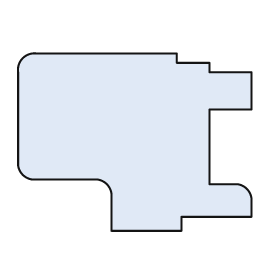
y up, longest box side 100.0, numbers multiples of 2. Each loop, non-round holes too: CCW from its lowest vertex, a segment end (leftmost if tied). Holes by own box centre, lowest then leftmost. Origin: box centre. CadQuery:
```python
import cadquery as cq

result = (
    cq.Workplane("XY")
    .moveTo(-10.0, -38.0)
    .lineTo(20.0, -38.0)
    .lineTo(20.0, -32.0)
    .lineTo(50.0, -32.0)
    .lineTo(50.0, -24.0)
    .threePointArc((48.0, -20.0), (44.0, -18.0))
    .lineTo(32.0, -18.0)
    .lineTo(32.0, 14.0)
    .lineTo(50.0, 14.0)
    .lineTo(50.0, 30.0)
    .lineTo(32.0, 30.0)
    .lineTo(32.0, 34.0)
    .lineTo(18.0, 34.0)
    .lineTo(18.0, 38.0)
    .lineTo(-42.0, 38.0)
    .threePointArc((-48.0, 36.0), (-50.0, 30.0))
    .lineTo(-50.0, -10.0)
    .threePointArc((-48.0, -14.0), (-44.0, -16.0))
    .lineTo(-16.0, -16.0)
    .threePointArc((-12.0, -18.0), (-10.0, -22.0))
    .close()
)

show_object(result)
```